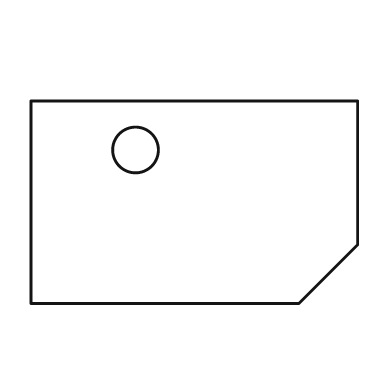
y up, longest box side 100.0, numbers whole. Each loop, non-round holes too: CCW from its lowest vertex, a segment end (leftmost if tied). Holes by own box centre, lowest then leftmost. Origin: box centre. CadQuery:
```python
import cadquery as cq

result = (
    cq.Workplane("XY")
    .moveTo(-50.0, -31.0)
    .lineTo(32.0, -31.0)
    .lineTo(50.0, -13.0)
    .lineTo(50.0, 31.0)
    .lineTo(-50.0, 31.0)
    .close()
    .moveTo(-18.0, 16.0)
    .circle(7.0)
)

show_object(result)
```